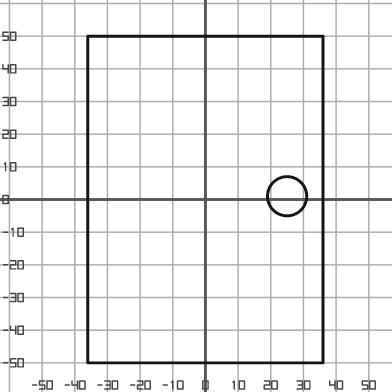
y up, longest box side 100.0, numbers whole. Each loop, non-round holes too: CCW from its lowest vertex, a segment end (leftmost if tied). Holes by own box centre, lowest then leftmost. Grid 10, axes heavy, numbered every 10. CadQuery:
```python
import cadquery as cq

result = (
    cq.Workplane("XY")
    .moveTo(-36.0, -50.0)
    .lineTo(36.0, -50.0)
    .lineTo(36.0, 50.0)
    .lineTo(-36.0, 50.0)
    .close()
    .moveTo(25.0, 1.0)
    .circle(6.0)
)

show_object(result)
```